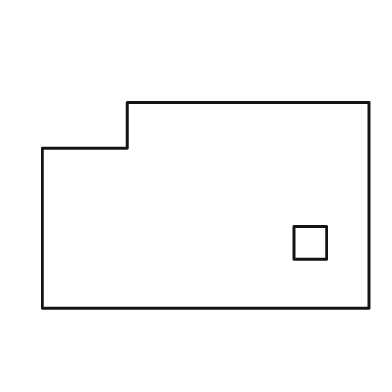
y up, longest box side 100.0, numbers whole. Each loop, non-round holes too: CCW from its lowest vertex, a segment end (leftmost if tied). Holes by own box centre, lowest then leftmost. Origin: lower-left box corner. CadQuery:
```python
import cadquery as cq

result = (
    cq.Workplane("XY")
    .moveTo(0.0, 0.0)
    .lineTo(100.0, 0.0)
    .lineTo(100.0, 63.0)
    .lineTo(26.0, 63.0)
    .lineTo(26.0, 49.0)
    .lineTo(0.0, 49.0)
    .close()
    .moveTo(77.0, 15.0)
    .lineTo(87.0, 15.0)
    .lineTo(87.0, 25.0)
    .lineTo(77.0, 25.0)
    .close()
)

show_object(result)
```